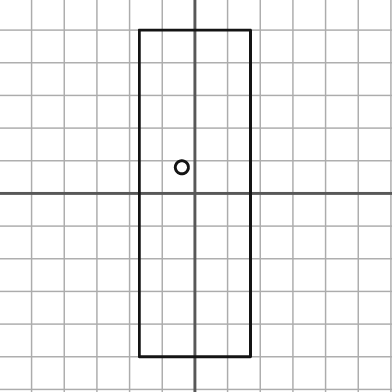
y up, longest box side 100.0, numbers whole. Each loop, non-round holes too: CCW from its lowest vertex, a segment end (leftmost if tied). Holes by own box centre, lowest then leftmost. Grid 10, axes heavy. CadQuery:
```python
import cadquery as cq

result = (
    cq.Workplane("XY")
    .moveTo(-17.0, -50.0)
    .lineTo(17.0, -50.0)
    .lineTo(17.0, 50.0)
    .lineTo(-17.0, 50.0)
    .close()
    .moveTo(-4.0, 8.0)
    .circle(2.0)
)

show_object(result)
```